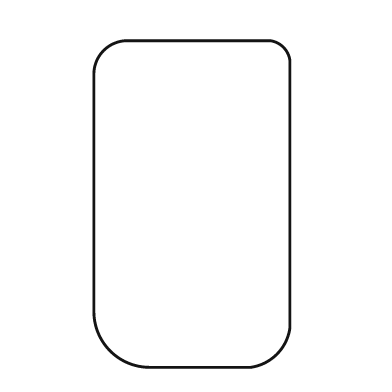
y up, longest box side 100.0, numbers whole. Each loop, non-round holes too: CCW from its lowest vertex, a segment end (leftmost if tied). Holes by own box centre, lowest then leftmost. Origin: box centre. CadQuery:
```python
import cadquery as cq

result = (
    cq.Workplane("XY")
    .moveTo(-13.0, -50.0)
    .lineTo(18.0, -50.0)
    .threePointArc((26.0, -46.0), (30.0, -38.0))
    .lineTo(30.0, 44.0)
    .threePointArc((28.0, 48.0), (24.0, 50.0))
    .lineTo(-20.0, 50.0)
    .threePointArc((-27.0, 47.0), (-30.0, 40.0))
    .lineTo(-30.0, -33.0)
    .threePointArc((-25.0, -45.0), (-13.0, -50.0))
    .close()
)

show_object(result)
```